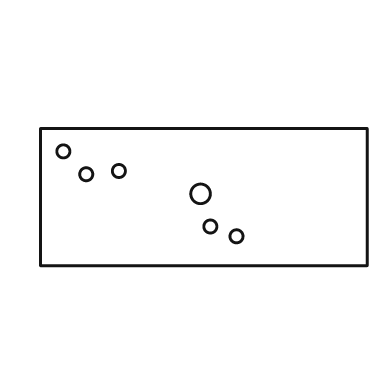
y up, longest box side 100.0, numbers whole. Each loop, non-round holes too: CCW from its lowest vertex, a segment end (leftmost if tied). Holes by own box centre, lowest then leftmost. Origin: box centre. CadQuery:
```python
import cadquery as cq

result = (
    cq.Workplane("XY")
    .moveTo(-50.0, -21.0)
    .lineTo(50.0, -21.0)
    .lineTo(50.0, 21.0)
    .lineTo(-50.0, 21.0)
    .close()
    .moveTo(10.0, -12.0)
    .circle(2.0)
    .moveTo(2.0, -9.0)
    .circle(2.0)
    .moveTo(-1.0, 1.0)
    .circle(3.0)
    .moveTo(-36.0, 7.0)
    .circle(2.0)
    .moveTo(-26.0, 8.0)
    .circle(2.0)
    .moveTo(-43.0, 14.0)
    .circle(2.0)
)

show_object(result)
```